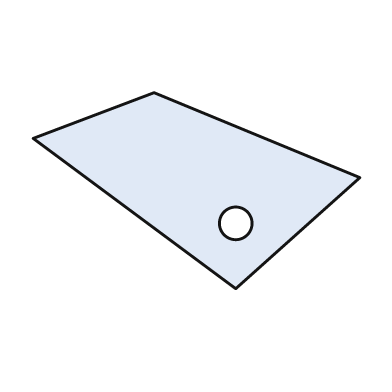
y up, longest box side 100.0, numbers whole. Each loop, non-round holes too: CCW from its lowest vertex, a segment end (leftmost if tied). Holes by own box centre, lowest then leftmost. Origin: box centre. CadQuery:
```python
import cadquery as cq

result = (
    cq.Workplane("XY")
    .moveTo(12.0, -30.0)
    .lineTo(50.0, 4.0)
    .lineTo(-13.0, 30.0)
    .lineTo(-50.0, 16.0)
    .close()
    .moveTo(12.0, -10.0)
    .circle(5.0)
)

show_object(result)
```